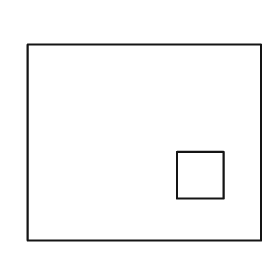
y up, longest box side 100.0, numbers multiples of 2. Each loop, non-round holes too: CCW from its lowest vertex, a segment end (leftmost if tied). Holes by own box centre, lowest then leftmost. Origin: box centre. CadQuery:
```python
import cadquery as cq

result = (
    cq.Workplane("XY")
    .moveTo(-50.0, -42.0)
    .lineTo(50.0, -42.0)
    .lineTo(50.0, 42.0)
    .lineTo(-50.0, 42.0)
    .close()
    .moveTo(14.0, -24.0)
    .lineTo(34.0, -24.0)
    .lineTo(34.0, -4.0)
    .lineTo(14.0, -4.0)
    .close()
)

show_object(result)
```